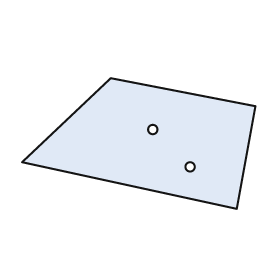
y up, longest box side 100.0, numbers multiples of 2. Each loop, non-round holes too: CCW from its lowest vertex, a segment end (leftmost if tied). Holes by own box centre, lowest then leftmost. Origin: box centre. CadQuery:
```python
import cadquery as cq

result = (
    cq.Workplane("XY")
    .moveTo(42.0, -28.0)
    .lineTo(50.0, 16.0)
    .lineTo(-12.0, 28.0)
    .lineTo(-50.0, -8.0)
    .close()
    .moveTo(22.0, -10.0)
    .circle(2.0)
    .moveTo(6.0, 6.0)
    .circle(2.0)
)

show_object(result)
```